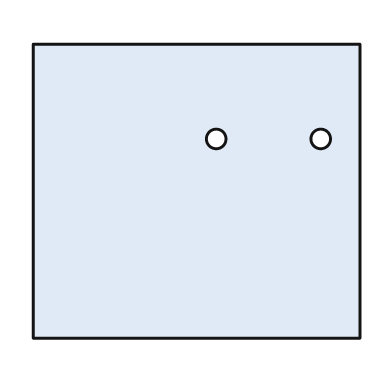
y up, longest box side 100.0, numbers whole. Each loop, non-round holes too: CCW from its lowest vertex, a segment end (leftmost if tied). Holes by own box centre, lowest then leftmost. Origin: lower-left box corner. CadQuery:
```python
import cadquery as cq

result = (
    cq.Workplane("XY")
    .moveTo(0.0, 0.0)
    .lineTo(100.0, 0.0)
    .lineTo(100.0, 90.0)
    .lineTo(0.0, 90.0)
    .close()
    .moveTo(56.0, 61.0)
    .circle(3.0)
    .moveTo(88.0, 61.0)
    .circle(3.0)
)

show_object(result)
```